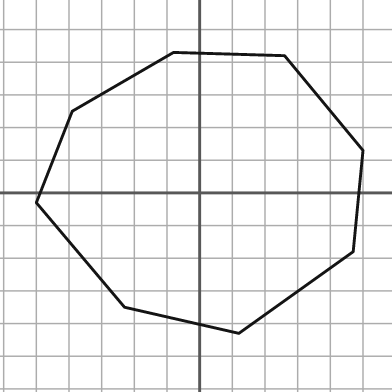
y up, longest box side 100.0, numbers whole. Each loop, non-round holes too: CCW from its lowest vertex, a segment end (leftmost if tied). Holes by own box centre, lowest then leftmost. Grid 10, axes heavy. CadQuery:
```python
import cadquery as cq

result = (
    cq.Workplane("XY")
    .moveTo(12.0, -43.0)
    .lineTo(47.0, -18.0)
    .lineTo(50.0, 13.0)
    .lineTo(26.0, 42.0)
    .lineTo(-8.0, 43.0)
    .lineTo(-39.0, 25.0)
    .lineTo(-50.0, -3.0)
    .lineTo(-23.0, -35.0)
    .close()
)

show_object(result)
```